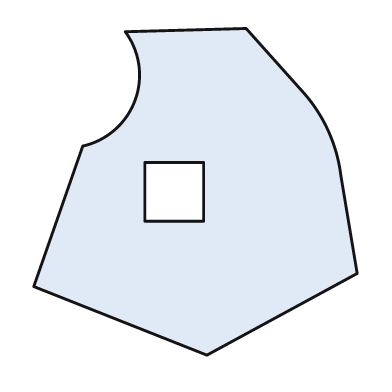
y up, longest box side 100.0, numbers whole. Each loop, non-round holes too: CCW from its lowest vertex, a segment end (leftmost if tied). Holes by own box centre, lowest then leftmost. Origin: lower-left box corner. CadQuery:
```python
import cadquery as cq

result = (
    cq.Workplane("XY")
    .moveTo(53.0, 0.0)
    .lineTo(99.0, 25.0)
    .lineTo(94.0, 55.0)
    .threePointArc((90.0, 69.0), (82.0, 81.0))
    .lineTo(65.0, 100.0)
    .lineTo(28.0, 99.0)
    .threePointArc((31.0, 78.0), (15.0, 64.0))
    .lineTo(0.0, 21.0)
    .close()
    .moveTo(34.0, 41.0)
    .lineTo(52.0, 41.0)
    .lineTo(52.0, 59.0)
    .lineTo(34.0, 59.0)
    .close()
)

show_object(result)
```